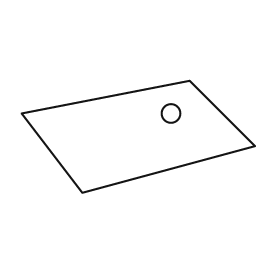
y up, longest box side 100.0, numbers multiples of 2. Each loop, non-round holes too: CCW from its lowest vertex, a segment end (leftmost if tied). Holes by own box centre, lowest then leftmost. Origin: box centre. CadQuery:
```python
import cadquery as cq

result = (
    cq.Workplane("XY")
    .moveTo(-24.0, -24.0)
    .lineTo(50.0, -4.0)
    .lineTo(22.0, 24.0)
    .lineTo(-50.0, 10.0)
    .close()
    .moveTo(14.0, 10.0)
    .circle(4.0)
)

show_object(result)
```